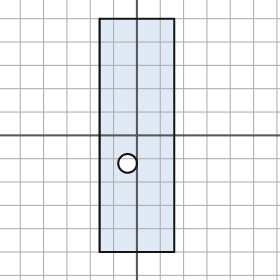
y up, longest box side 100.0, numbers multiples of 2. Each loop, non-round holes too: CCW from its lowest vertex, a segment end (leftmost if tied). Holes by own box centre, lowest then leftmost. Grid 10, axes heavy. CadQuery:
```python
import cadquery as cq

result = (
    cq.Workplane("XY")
    .moveTo(-16.0, -50.0)
    .lineTo(16.0, -50.0)
    .lineTo(16.0, 50.0)
    .lineTo(-16.0, 50.0)
    .close()
    .moveTo(-4.0, -12.0)
    .circle(4.0)
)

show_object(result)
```